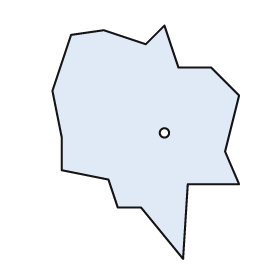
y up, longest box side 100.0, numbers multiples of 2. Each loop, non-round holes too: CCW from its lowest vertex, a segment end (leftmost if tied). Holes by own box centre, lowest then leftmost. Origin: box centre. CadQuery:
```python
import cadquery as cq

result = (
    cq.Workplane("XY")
    .moveTo(16.0, -50.0)
    .lineTo(18.0, -18.0)
    .lineTo(40.0, -18.0)
    .lineTo(34.0, -4.0)
    .lineTo(40.0, 20.0)
    .lineTo(28.0, 32.0)
    .lineTo(14.0, 32.0)
    .lineTo(8.0, 50.0)
    .lineTo(0.0, 42.0)
    .lineTo(-18.0, 48.0)
    .lineTo(-32.0, 46.0)
    .lineTo(-40.0, 22.0)
    .lineTo(-36.0, 2.0)
    .lineTo(-36.0, -12.0)
    .lineTo(-16.0, -16.0)
    .lineTo(-12.0, -28.0)
    .lineTo(-2.0, -28.0)
    .close()
    .moveTo(8.0, 4.0)
    .circle(2.0)
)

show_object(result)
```